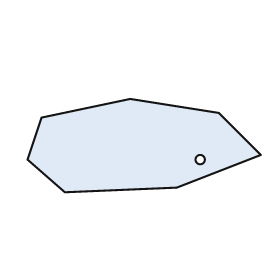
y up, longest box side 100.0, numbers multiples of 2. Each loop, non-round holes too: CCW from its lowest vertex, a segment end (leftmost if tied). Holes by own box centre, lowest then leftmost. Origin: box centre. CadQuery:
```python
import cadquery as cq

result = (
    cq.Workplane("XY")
    .moveTo(-34.0, -20.0)
    .lineTo(14.0, -18.0)
    .lineTo(50.0, -4.0)
    .lineTo(32.0, 14.0)
    .lineTo(-6.0, 20.0)
    .lineTo(-44.0, 12.0)
    .lineTo(-50.0, -6.0)
    .close()
    .moveTo(24.0, -6.0)
    .circle(2.0)
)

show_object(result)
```